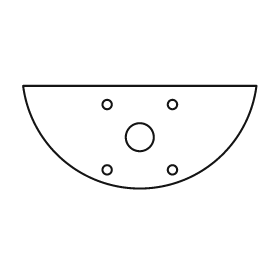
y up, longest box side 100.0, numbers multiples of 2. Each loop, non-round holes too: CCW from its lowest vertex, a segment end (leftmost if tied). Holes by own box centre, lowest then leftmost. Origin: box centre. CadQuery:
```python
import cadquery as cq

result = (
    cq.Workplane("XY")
    .moveTo(-50.0, 22.0)
    .threePointArc((0.0, -22.0), (50.0, 22.0))
    .close()
    .moveTo(-14.0, -14.0)
    .circle(2.0)
    .moveTo(14.0, -14.0)
    .circle(2.0)
    .moveTo(0.0, 0.0)
    .circle(6.0)
    .moveTo(-14.0, 14.0)
    .circle(2.0)
    .moveTo(14.0, 14.0)
    .circle(2.0)
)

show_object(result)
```